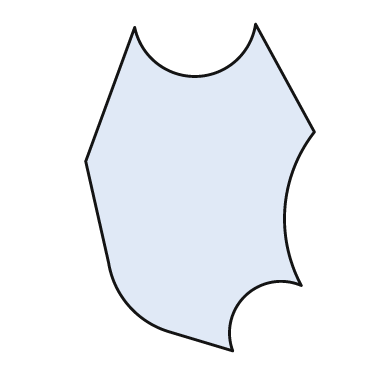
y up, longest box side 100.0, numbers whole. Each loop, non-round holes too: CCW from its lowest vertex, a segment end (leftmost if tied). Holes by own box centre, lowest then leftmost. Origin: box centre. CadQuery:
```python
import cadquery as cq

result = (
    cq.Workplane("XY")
    .moveTo(10.0, -50.0)
    .threePointArc((14.0, -33.0), (31.0, -30.0))
    .threePointArc((26.0, -6.0), (35.0, 17.0))
    .lineTo(17.0, 50.0)
    .threePointArc((-1.0, 34.0), (-20.0, 49.0))
    .lineTo(-35.0, 8.0)
    .lineTo(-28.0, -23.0)
    .threePointArc((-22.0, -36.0), (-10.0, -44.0))
    .close()
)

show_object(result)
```